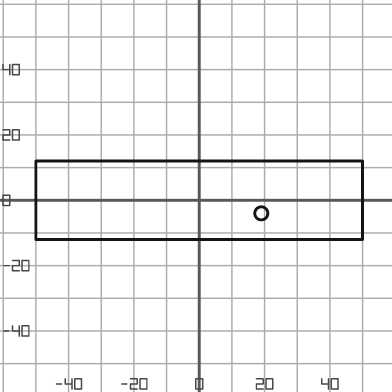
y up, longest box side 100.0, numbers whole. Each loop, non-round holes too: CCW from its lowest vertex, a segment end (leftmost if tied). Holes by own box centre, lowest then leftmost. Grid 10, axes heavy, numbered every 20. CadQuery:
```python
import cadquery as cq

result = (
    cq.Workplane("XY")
    .moveTo(-50.0, -12.0)
    .lineTo(50.0, -12.0)
    .lineTo(50.0, 12.0)
    .lineTo(-50.0, 12.0)
    .close()
    .moveTo(19.0, -4.0)
    .circle(2.0)
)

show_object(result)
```